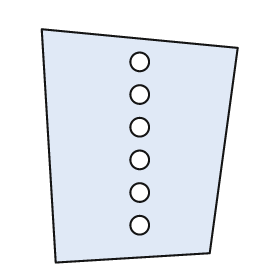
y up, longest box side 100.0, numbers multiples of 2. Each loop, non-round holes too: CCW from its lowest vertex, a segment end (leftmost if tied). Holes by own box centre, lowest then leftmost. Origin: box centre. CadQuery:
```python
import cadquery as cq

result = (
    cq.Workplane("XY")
    .moveTo(-36.0, -50.0)
    .lineTo(30.0, -46.0)
    .lineTo(42.0, 42.0)
    .lineTo(-42.0, 50.0)
    .close()
    .moveTo(0.0, -34.0)
    .circle(4.0)
    .moveTo(0.0, -20.0)
    .circle(4.0)
    .moveTo(0.0, -6.0)
    .circle(4.0)
    .moveTo(0.0, 8.0)
    .circle(4.0)
    .moveTo(0.0, 22.0)
    .circle(4.0)
    .moveTo(0.0, 36.0)
    .circle(4.0)
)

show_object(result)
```